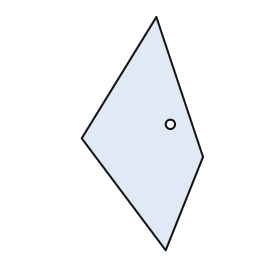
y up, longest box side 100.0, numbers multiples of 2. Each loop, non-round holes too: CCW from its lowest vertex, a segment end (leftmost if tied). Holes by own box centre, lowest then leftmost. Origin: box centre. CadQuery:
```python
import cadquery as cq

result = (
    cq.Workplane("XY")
    .moveTo(10.0, -50.0)
    .lineTo(26.0, -10.0)
    .lineTo(6.0, 50.0)
    .lineTo(-26.0, -2.0)
    .close()
    .moveTo(12.0, 4.0)
    .circle(2.0)
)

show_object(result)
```